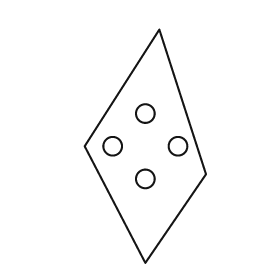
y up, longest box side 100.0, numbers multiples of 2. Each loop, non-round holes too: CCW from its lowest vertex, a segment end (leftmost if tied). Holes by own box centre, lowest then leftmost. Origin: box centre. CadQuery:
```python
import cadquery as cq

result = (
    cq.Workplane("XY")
    .moveTo(0.0, -50.0)
    .lineTo(26.0, -12.0)
    .lineTo(6.0, 50.0)
    .lineTo(-26.0, 0.0)
    .close()
    .moveTo(0.0, -14.0)
    .circle(4.0)
    .moveTo(-14.0, 0.0)
    .circle(4.0)
    .moveTo(14.0, 0.0)
    .circle(4.0)
    .moveTo(0.0, 14.0)
    .circle(4.0)
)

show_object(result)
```